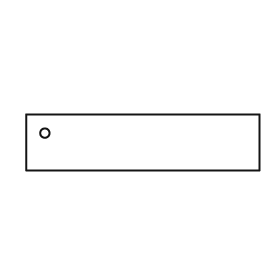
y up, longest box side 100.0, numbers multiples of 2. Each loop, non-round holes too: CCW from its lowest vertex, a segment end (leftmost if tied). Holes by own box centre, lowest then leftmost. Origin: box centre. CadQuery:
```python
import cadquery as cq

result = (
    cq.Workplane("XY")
    .moveTo(-50.0, -12.0)
    .lineTo(50.0, -12.0)
    .lineTo(50.0, 12.0)
    .lineTo(-50.0, 12.0)
    .close()
    .moveTo(-42.0, 4.0)
    .circle(2.0)
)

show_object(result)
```